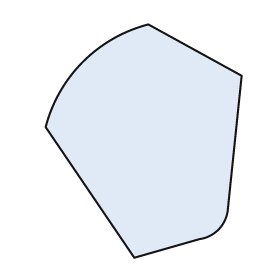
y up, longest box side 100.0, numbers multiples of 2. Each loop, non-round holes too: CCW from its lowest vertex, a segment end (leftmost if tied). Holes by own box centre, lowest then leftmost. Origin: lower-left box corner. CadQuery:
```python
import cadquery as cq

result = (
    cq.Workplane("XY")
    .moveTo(38.0, 0.0)
    .lineTo(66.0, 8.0)
    .threePointArc((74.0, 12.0), (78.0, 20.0))
    .lineTo(84.0, 78.0)
    .lineTo(44.0, 100.0)
    .threePointArc((16.0, 84.0), (0.0, 56.0))
    .close()
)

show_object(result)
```